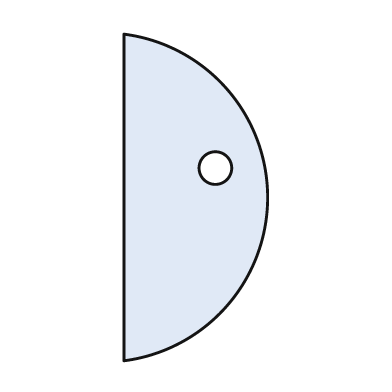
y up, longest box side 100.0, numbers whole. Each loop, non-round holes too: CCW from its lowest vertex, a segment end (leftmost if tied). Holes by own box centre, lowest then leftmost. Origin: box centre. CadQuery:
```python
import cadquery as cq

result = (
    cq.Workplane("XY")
    .moveTo(-22.0, -50.0)
    .threePointArc((22.0, 0.0), (-22.0, 50.0))
    .close()
    .moveTo(6.0, 9.0)
    .circle(5.0)
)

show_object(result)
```